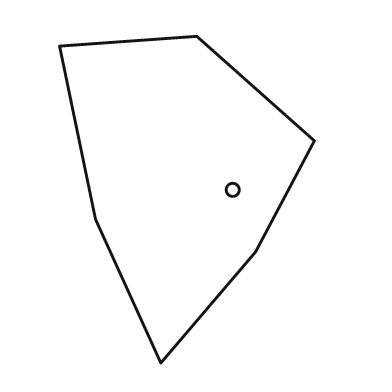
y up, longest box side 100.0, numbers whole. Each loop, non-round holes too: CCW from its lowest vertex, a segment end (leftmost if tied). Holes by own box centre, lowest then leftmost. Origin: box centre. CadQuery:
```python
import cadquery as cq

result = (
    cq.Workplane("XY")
    .moveTo(-8.0, -50.0)
    .lineTo(21.0, -16.0)
    .lineTo(39.0, 18.0)
    .lineTo(3.0, 50.0)
    .lineTo(-39.0, 47.0)
    .lineTo(-28.0, -6.0)
    .close()
    .moveTo(14.0, 3.0)
    .circle(2.0)
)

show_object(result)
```